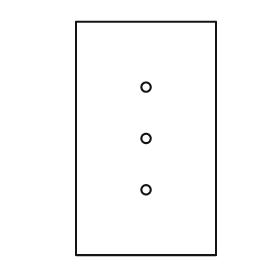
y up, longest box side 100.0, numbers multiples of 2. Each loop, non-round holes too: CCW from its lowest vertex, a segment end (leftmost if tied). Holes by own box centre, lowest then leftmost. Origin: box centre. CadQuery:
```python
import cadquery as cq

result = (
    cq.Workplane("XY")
    .moveTo(-30.0, -50.0)
    .lineTo(30.0, -50.0)
    .lineTo(30.0, 50.0)
    .lineTo(-30.0, 50.0)
    .close()
    .moveTo(0.0, -22.0)
    .circle(2.0)
    .moveTo(0.0, 0.0)
    .circle(2.0)
    .moveTo(0.0, 22.0)
    .circle(2.0)
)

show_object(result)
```